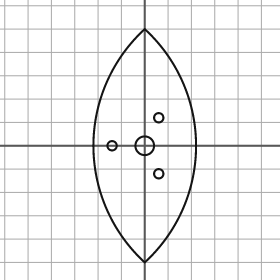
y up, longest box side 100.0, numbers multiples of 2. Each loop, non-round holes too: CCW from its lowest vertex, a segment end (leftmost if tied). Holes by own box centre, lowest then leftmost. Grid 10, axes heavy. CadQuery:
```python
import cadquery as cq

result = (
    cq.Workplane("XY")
    .moveTo(0.0, -50.0)
    .threePointArc((22.0, 0.0), (0.0, 50.0))
    .threePointArc((-22.0, 0.0), (0.0, -50.0))
    .close()
    .moveTo(6.0, -12.0)
    .circle(2.0)
    .moveTo(-14.0, 0.0)
    .circle(2.0)
    .moveTo(0.0, 0.0)
    .circle(4.0)
    .moveTo(6.0, 12.0)
    .circle(2.0)
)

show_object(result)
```